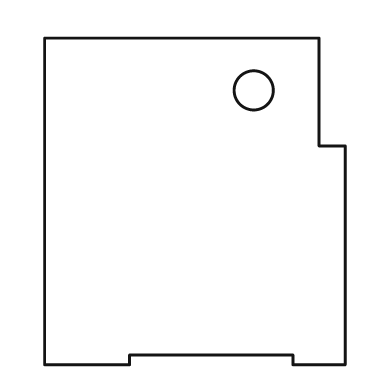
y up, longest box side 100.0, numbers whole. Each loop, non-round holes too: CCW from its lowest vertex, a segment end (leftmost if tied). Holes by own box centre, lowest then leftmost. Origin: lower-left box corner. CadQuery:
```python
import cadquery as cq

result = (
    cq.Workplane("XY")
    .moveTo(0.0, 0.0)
    .lineTo(26.0, 0.0)
    .lineTo(26.0, 3.0)
    .lineTo(76.0, 3.0)
    .lineTo(76.0, 0.0)
    .lineTo(92.0, 0.0)
    .lineTo(92.0, 67.0)
    .lineTo(84.0, 67.0)
    .lineTo(84.0, 100.0)
    .lineTo(0.0, 100.0)
    .close()
    .moveTo(64.0, 84.0)
    .circle(6.0)
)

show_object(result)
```